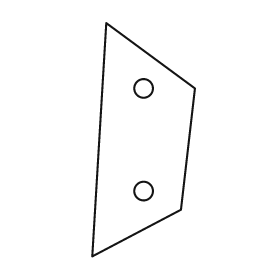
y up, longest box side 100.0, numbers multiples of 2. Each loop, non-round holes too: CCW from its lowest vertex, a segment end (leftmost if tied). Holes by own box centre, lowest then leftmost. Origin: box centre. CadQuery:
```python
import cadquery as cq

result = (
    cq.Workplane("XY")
    .moveTo(-22.0, -50.0)
    .lineTo(16.0, -30.0)
    .lineTo(22.0, 22.0)
    .lineTo(-16.0, 50.0)
    .close()
    .moveTo(0.0, -22.0)
    .circle(4.0)
    .moveTo(0.0, 22.0)
    .circle(4.0)
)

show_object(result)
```